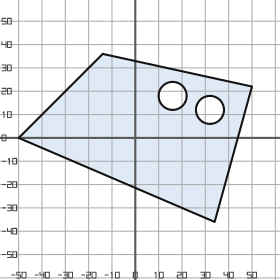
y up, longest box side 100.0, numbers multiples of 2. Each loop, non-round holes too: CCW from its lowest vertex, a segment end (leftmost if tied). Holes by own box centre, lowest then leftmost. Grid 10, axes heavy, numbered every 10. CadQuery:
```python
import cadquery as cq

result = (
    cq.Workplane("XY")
    .moveTo(34.0, -36.0)
    .lineTo(50.0, 22.0)
    .lineTo(-14.0, 36.0)
    .lineTo(-50.0, 0.0)
    .close()
    .moveTo(32.0, 12.0)
    .circle(6.0)
    .moveTo(16.0, 18.0)
    .circle(6.0)
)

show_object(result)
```